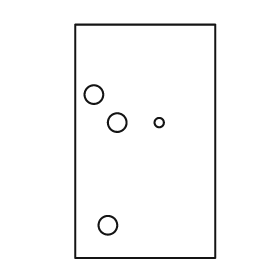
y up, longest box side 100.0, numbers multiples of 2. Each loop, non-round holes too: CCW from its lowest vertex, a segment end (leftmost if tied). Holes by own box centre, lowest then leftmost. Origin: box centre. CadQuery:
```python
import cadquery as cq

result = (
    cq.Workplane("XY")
    .moveTo(-30.0, -50.0)
    .lineTo(30.0, -50.0)
    .lineTo(30.0, 50.0)
    .lineTo(-30.0, 50.0)
    .close()
    .moveTo(-16.0, -36.0)
    .circle(4.0)
    .moveTo(-12.0, 8.0)
    .circle(4.0)
    .moveTo(6.0, 8.0)
    .circle(2.0)
    .moveTo(-22.0, 20.0)
    .circle(4.0)
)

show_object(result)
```